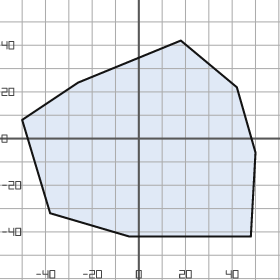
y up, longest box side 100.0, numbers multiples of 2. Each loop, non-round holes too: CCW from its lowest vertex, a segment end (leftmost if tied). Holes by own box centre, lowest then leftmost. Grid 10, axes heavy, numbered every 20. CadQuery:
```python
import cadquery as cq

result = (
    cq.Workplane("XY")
    .moveTo(-4.0, -42.0)
    .lineTo(48.0, -42.0)
    .lineTo(50.0, -6.0)
    .lineTo(42.0, 22.0)
    .lineTo(18.0, 42.0)
    .lineTo(-26.0, 24.0)
    .lineTo(-50.0, 8.0)
    .lineTo(-38.0, -32.0)
    .close()
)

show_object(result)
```